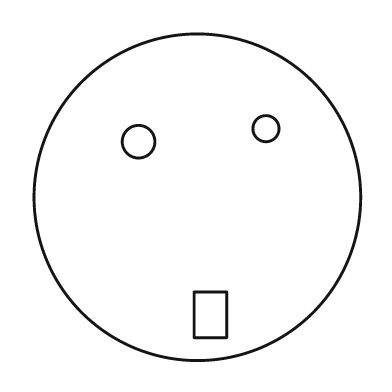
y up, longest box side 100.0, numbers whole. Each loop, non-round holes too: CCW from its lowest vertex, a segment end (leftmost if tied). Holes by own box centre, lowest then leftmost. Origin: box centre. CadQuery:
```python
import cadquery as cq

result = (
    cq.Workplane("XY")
    .moveTo(0.0, 0.0)
    .circle(50.0)
    .moveTo(-1.0, -43.0)
    .lineTo(9.0, -43.0)
    .lineTo(9.0, -29.0)
    .lineTo(-1.0, -29.0)
    .close()
    .moveTo(-18.0, 17.0)
    .circle(5.0)
    .moveTo(21.0, 21.0)
    .circle(4.0)
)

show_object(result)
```